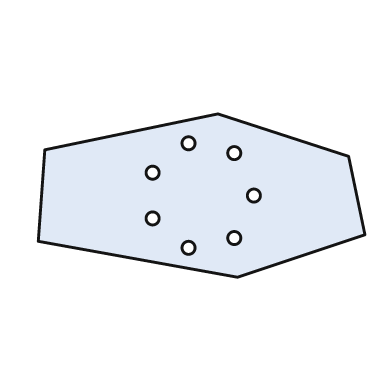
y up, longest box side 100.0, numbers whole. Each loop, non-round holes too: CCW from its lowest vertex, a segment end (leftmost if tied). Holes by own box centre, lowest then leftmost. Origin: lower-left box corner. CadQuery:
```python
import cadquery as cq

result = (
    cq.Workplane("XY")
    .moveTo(61.0, 0.0)
    .lineTo(100.0, 13.0)
    .lineTo(95.0, 37.0)
    .lineTo(55.0, 50.0)
    .lineTo(2.0, 39.0)
    .lineTo(0.0, 11.0)
    .close()
    .moveTo(46.0, 9.0)
    .circle(2.0)
    .moveTo(60.0, 12.0)
    .circle(2.0)
    .moveTo(35.0, 18.0)
    .circle(2.0)
    .moveTo(66.0, 25.0)
    .circle(2.0)
    .moveTo(35.0, 32.0)
    .circle(2.0)
    .moveTo(60.0, 38.0)
    .circle(2.0)
    .moveTo(46.0, 41.0)
    .circle(2.0)
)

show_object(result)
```